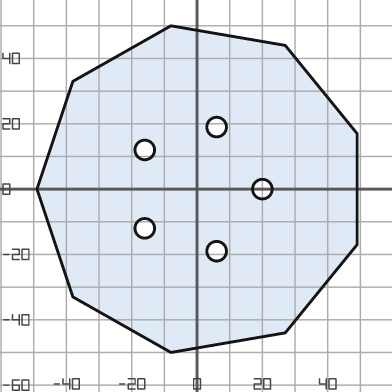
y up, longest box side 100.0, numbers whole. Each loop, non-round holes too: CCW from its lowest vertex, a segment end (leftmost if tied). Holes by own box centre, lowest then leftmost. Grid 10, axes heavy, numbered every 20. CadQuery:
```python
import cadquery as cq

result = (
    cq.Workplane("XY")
    .moveTo(-8.0, -50.0)
    .lineTo(27.0, -44.0)
    .lineTo(49.0, -17.0)
    .lineTo(49.0, 17.0)
    .lineTo(27.0, 44.0)
    .lineTo(-8.0, 50.0)
    .lineTo(-38.0, 33.0)
    .lineTo(-49.0, 0.0)
    .lineTo(-38.0, -33.0)
    .close()
    .moveTo(6.0, -19.0)
    .circle(3.0)
    .moveTo(-16.0, -12.0)
    .circle(3.0)
    .moveTo(20.0, 0.0)
    .circle(3.0)
    .moveTo(-16.0, 12.0)
    .circle(3.0)
    .moveTo(6.0, 19.0)
    .circle(3.0)
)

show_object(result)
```